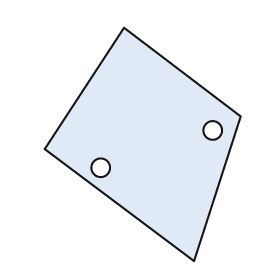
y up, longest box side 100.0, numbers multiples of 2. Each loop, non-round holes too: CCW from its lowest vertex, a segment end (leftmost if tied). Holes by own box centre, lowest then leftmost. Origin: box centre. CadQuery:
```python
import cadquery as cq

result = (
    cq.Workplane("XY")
    .moveTo(22.0, -50.0)
    .lineTo(42.0, 12.0)
    .lineTo(-8.0, 50.0)
    .lineTo(-42.0, -2.0)
    .close()
    .moveTo(-18.0, -10.0)
    .circle(4.0)
    .moveTo(30.0, 6.0)
    .circle(4.0)
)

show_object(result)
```